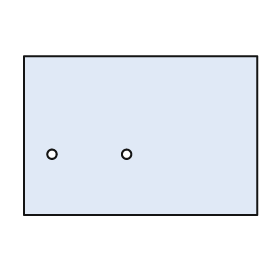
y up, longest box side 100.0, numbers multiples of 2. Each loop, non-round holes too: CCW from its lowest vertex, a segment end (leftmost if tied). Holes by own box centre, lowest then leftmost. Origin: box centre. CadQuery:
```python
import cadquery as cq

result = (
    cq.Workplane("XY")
    .moveTo(-50.0, -34.0)
    .lineTo(50.0, -34.0)
    .lineTo(50.0, 34.0)
    .lineTo(-50.0, 34.0)
    .close()
    .moveTo(-38.0, -8.0)
    .circle(2.0)
    .moveTo(-6.0, -8.0)
    .circle(2.0)
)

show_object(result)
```